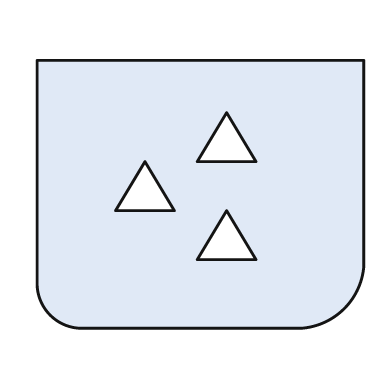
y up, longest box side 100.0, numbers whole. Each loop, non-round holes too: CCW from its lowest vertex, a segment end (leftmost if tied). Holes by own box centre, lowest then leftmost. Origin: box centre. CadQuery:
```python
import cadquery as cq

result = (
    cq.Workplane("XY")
    .moveTo(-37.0, -41.0)
    .lineTo(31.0, -41.0)
    .threePointArc((44.0, -35.0), (50.0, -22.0))
    .lineTo(50.0, 41.0)
    .lineTo(-50.0, 41.0)
    .lineTo(-50.0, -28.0)
    .threePointArc((-46.0, -37.0), (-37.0, -41.0))
    .close()
    .moveTo(-1.0, -20.0)
    .lineTo(17.0, -20.0)
    .lineTo(8.0, -5.0)
    .close()
    .moveTo(-26.0, -5.0)
    .lineTo(-8.0, -5.0)
    .lineTo(-17.0, 10.0)
    .close()
    .moveTo(-1.0, 10.0)
    .lineTo(17.0, 10.0)
    .lineTo(8.0, 25.0)
    .close()
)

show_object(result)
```